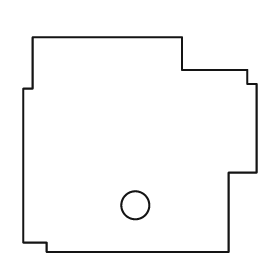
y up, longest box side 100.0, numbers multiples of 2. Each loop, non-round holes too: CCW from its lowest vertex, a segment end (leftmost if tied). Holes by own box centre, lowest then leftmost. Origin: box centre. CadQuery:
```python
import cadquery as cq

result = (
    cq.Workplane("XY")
    .moveTo(-40.0, -46.0)
    .lineTo(38.0, -46.0)
    .lineTo(38.0, -12.0)
    .lineTo(50.0, -12.0)
    .lineTo(50.0, 26.0)
    .lineTo(46.0, 26.0)
    .lineTo(46.0, 32.0)
    .lineTo(18.0, 32.0)
    .lineTo(18.0, 46.0)
    .lineTo(-46.0, 46.0)
    .lineTo(-46.0, 24.0)
    .lineTo(-50.0, 24.0)
    .lineTo(-50.0, -42.0)
    .lineTo(-40.0, -42.0)
    .close()
    .moveTo(-2.0, -26.0)
    .circle(6.0)
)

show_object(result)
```